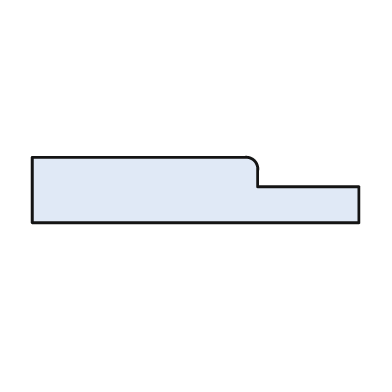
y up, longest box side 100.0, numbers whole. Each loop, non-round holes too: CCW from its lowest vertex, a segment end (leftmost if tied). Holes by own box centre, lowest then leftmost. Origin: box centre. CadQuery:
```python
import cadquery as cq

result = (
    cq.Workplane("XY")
    .moveTo(-50.0, -10.0)
    .lineTo(50.0, -10.0)
    .lineTo(50.0, 1.0)
    .lineTo(19.0, 1.0)
    .lineTo(19.0, 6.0)
    .threePointArc((18.0, 9.0), (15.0, 10.0))
    .lineTo(-50.0, 10.0)
    .close()
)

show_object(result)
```